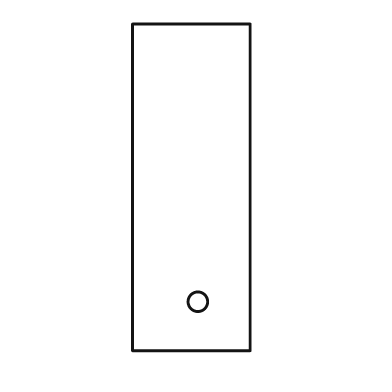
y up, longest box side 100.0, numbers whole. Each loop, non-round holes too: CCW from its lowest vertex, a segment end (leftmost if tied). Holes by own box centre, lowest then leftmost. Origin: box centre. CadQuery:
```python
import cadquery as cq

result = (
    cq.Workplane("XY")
    .moveTo(-18.0, -50.0)
    .lineTo(18.0, -50.0)
    .lineTo(18.0, 50.0)
    .lineTo(-18.0, 50.0)
    .close()
    .moveTo(2.0, -35.0)
    .circle(3.0)
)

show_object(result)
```